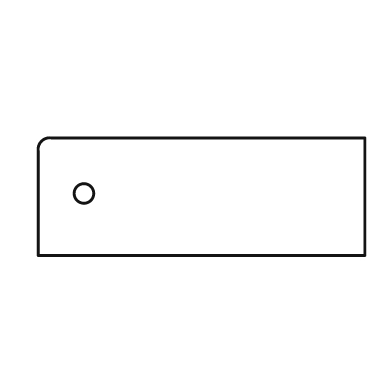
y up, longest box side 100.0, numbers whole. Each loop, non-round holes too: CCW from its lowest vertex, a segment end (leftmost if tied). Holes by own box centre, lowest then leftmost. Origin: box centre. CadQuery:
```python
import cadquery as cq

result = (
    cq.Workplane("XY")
    .moveTo(-50.0, -18.0)
    .lineTo(50.0, -18.0)
    .lineTo(50.0, 18.0)
    .lineTo(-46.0, 18.0)
    .threePointArc((-49.0, 17.0), (-50.0, 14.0))
    .close()
    .moveTo(-36.0, 1.0)
    .circle(3.0)
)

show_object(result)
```